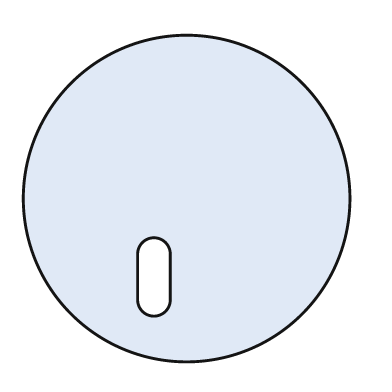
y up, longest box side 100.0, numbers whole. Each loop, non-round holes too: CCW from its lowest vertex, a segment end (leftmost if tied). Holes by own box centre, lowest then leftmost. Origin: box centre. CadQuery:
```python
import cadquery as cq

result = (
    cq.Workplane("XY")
    .moveTo(0.0, 0.0)
    .circle(50.0)
    .moveTo(-15.0, -31.0)
    .threePointArc((-10.0, -36.0), (-5.0, -31.0))
    .lineTo(-5.0, -17.0)
    .threePointArc((-10.0, -12.0), (-15.0, -17.0))
    .close()
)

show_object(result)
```